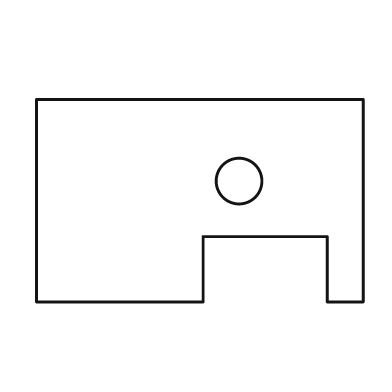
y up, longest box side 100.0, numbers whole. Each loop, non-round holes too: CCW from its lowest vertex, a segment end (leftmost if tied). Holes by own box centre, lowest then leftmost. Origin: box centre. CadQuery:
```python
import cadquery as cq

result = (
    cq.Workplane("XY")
    .moveTo(-50.0, -31.0)
    .lineTo(1.0, -31.0)
    .lineTo(1.0, -11.0)
    .lineTo(39.0, -11.0)
    .lineTo(39.0, -31.0)
    .lineTo(50.0, -31.0)
    .lineTo(50.0, 31.0)
    .lineTo(-50.0, 31.0)
    .close()
    .moveTo(12.0, 6.0)
    .circle(7.0)
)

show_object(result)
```